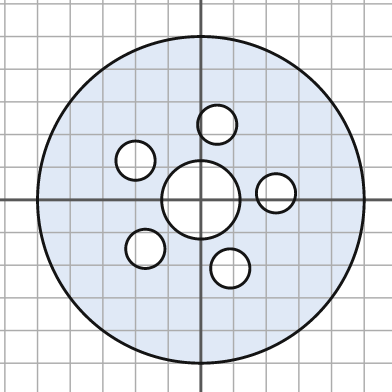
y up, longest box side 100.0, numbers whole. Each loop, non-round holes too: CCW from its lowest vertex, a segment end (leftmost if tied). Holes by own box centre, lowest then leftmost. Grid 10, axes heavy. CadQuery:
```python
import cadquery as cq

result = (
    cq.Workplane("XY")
    .moveTo(0.0, 0.0)
    .circle(50.0)
    .moveTo(9.0, -21.0)
    .circle(6.0)
    .moveTo(-17.0, -15.0)
    .circle(6.0)
    .moveTo(0.0, 0.0)
    .circle(12.0)
    .moveTo(23.0, 2.0)
    .circle(6.0)
    .moveTo(-20.0, 12.0)
    .circle(6.0)
    .moveTo(5.0, 23.0)
    .circle(6.0)
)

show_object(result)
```